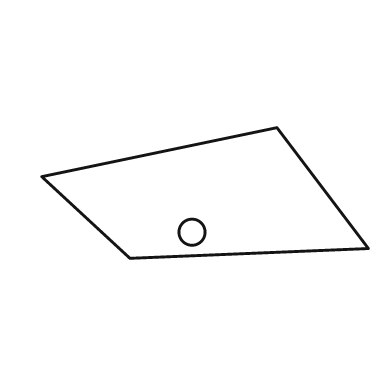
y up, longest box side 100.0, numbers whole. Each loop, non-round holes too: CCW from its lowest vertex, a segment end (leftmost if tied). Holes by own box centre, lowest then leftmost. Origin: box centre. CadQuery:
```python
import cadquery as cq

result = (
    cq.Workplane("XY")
    .moveTo(-23.0, -20.0)
    .lineTo(50.0, -17.0)
    .lineTo(22.0, 20.0)
    .lineTo(-50.0, 5.0)
    .close()
    .moveTo(-4.0, -12.0)
    .circle(4.0)
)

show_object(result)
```